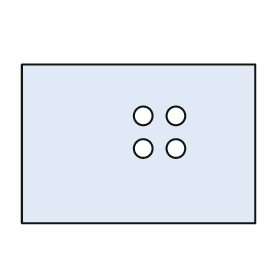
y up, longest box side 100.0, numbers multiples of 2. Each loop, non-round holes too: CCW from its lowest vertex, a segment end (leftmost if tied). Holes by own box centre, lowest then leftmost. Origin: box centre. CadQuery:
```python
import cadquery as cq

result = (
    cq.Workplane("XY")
    .moveTo(-50.0, -34.0)
    .lineTo(50.0, -34.0)
    .lineTo(50.0, 34.0)
    .lineTo(-50.0, 34.0)
    .close()
    .moveTo(2.0, -2.0)
    .circle(4.0)
    .moveTo(16.0, -2.0)
    .circle(4.0)
    .moveTo(2.0, 12.0)
    .circle(4.0)
    .moveTo(16.0, 12.0)
    .circle(4.0)
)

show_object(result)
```